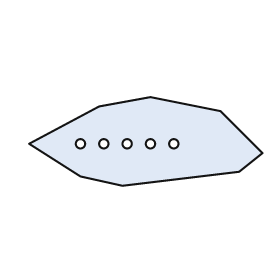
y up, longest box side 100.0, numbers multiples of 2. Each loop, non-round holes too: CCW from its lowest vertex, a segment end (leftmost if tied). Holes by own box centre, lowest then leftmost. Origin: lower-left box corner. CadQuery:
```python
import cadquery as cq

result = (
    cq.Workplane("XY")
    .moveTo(40.0, 0.0)
    .lineTo(90.0, 6.0)
    .lineTo(100.0, 14.0)
    .lineTo(82.0, 32.0)
    .lineTo(52.0, 38.0)
    .lineTo(30.0, 34.0)
    .lineTo(0.0, 18.0)
    .lineTo(22.0, 4.0)
    .close()
    .moveTo(22.0, 18.0)
    .circle(2.0)
    .moveTo(32.0, 18.0)
    .circle(2.0)
    .moveTo(42.0, 18.0)
    .circle(2.0)
    .moveTo(52.0, 18.0)
    .circle(2.0)
    .moveTo(62.0, 18.0)
    .circle(2.0)
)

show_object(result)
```